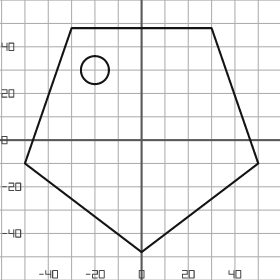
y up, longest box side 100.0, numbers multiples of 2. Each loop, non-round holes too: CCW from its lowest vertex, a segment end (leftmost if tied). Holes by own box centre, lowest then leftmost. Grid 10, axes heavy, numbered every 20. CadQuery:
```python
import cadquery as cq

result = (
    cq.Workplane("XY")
    .moveTo(0.0, -48.0)
    .lineTo(50.0, -10.0)
    .lineTo(30.0, 48.0)
    .lineTo(-30.0, 48.0)
    .lineTo(-50.0, -10.0)
    .close()
    .moveTo(-20.0, 30.0)
    .circle(6.0)
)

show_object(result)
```